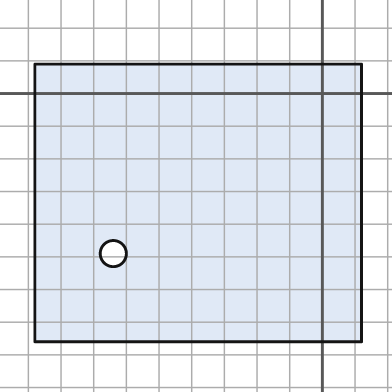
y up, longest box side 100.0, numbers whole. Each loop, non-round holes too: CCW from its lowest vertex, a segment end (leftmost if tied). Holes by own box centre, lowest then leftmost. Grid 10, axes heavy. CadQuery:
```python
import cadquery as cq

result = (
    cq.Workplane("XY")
    .moveTo(-88.0, -76.0)
    .lineTo(12.0, -76.0)
    .lineTo(12.0, 9.0)
    .lineTo(-88.0, 9.0)
    .close()
    .moveTo(-64.0, -49.0)
    .circle(4.0)
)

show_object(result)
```